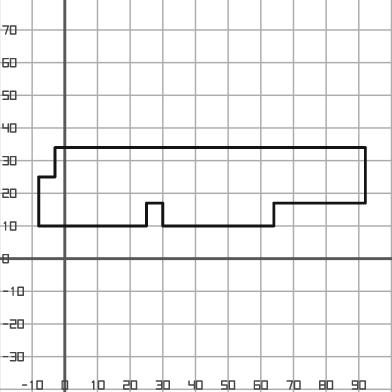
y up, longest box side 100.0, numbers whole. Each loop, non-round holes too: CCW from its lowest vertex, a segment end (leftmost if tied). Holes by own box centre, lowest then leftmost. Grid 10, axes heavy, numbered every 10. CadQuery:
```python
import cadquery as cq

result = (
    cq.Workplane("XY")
    .moveTo(-8.0, 10.0)
    .lineTo(25.0, 10.0)
    .lineTo(25.0, 17.0)
    .lineTo(30.0, 17.0)
    .lineTo(30.0, 10.0)
    .lineTo(64.0, 10.0)
    .lineTo(64.0, 17.0)
    .lineTo(92.0, 17.0)
    .lineTo(92.0, 34.0)
    .lineTo(-3.0, 34.0)
    .lineTo(-3.0, 25.0)
    .lineTo(-8.0, 25.0)
    .close()
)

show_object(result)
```